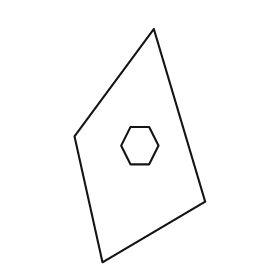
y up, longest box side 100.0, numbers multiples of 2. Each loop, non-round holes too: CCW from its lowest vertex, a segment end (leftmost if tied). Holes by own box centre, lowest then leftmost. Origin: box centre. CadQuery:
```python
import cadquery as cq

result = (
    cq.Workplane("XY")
    .moveTo(-16.0, -50.0)
    .lineTo(28.0, -24.0)
    .lineTo(6.0, 50.0)
    .lineTo(-28.0, 4.0)
    .close()
    .moveTo(-4.0, -8.0)
    .lineTo(4.0, -8.0)
    .lineTo(8.0, 0.0)
    .lineTo(4.0, 8.0)
    .lineTo(-4.0, 8.0)
    .lineTo(-8.0, 0.0)
    .close()
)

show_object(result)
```